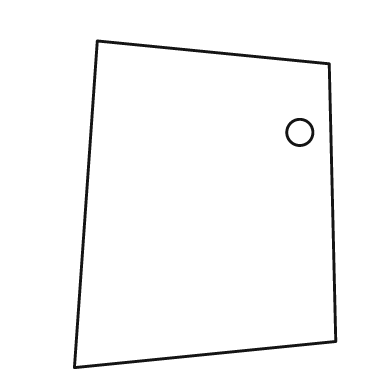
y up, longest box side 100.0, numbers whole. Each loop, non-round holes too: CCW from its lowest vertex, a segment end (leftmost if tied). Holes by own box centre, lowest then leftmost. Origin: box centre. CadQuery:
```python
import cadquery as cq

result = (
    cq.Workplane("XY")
    .moveTo(-40.0, -50.0)
    .lineTo(40.0, -42.0)
    .lineTo(38.0, 43.0)
    .lineTo(-33.0, 50.0)
    .close()
    .moveTo(29.0, 22.0)
    .circle(4.0)
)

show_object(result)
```